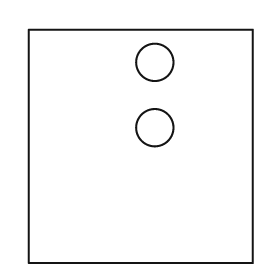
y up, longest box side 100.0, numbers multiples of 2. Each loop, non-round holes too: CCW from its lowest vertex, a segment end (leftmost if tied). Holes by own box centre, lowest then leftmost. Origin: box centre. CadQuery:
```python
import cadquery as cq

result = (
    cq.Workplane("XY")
    .moveTo(-48.0, -50.0)
    .lineTo(48.0, -50.0)
    .lineTo(48.0, 50.0)
    .lineTo(-48.0, 50.0)
    .close()
    .moveTo(6.0, 8.0)
    .circle(8.0)
    .moveTo(6.0, 36.0)
    .circle(8.0)
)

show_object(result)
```